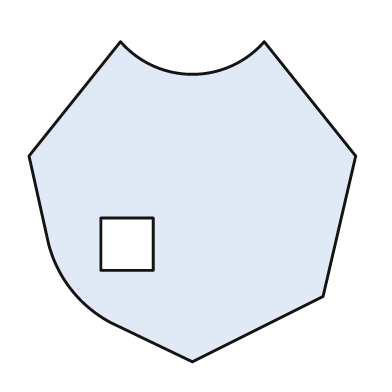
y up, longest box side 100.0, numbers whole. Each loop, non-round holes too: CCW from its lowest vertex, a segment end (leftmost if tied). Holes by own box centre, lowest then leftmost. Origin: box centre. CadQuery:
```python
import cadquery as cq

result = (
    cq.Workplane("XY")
    .moveTo(0.0, -49.0)
    .lineTo(40.0, -29.0)
    .lineTo(50.0, 14.0)
    .lineTo(22.0, 49.0)
    .threePointArc((0.0, 39.0), (-22.0, 49.0))
    .lineTo(-50.0, 14.0)
    .lineTo(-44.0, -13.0)
    .threePointArc((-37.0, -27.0), (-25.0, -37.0))
    .close()
    .moveTo(-28.0, -21.0)
    .lineTo(-12.0, -21.0)
    .lineTo(-12.0, -5.0)
    .lineTo(-28.0, -5.0)
    .close()
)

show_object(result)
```